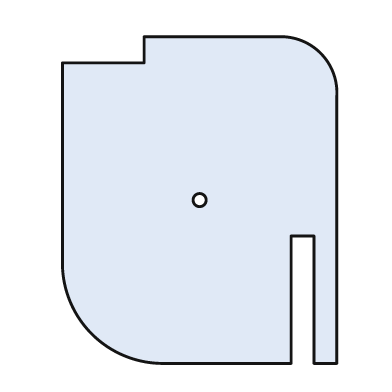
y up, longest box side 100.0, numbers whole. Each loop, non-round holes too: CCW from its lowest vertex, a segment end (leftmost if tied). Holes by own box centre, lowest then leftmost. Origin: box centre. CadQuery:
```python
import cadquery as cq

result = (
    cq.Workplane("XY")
    .moveTo(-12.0, -50.0)
    .lineTo(28.0, -50.0)
    .lineTo(28.0, -11.0)
    .lineTo(35.0, -11.0)
    .lineTo(35.0, -50.0)
    .lineTo(42.0, -50.0)
    .lineTo(42.0, 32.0)
    .threePointArc((37.0, 45.0), (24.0, 50.0))
    .lineTo(-17.0, 50.0)
    .lineTo(-17.0, 42.0)
    .lineTo(-42.0, 42.0)
    .lineTo(-42.0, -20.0)
    .threePointArc((-33.0, -41.0), (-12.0, -50.0))
    .close()
    .moveTo(0.0, 0.0)
    .circle(2.0)
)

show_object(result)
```